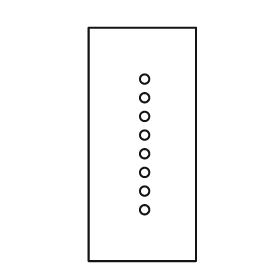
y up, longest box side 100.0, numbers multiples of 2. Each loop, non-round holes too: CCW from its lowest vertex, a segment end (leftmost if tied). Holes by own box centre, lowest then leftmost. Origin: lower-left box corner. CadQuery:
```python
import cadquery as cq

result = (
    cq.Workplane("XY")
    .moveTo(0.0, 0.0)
    .lineTo(46.0, 0.0)
    .lineTo(46.0, 100.0)
    .lineTo(0.0, 100.0)
    .close()
    .moveTo(24.0, 22.0)
    .circle(2.0)
    .moveTo(24.0, 30.0)
    .circle(2.0)
    .moveTo(24.0, 38.0)
    .circle(2.0)
    .moveTo(24.0, 46.0)
    .circle(2.0)
    .moveTo(24.0, 54.0)
    .circle(2.0)
    .moveTo(24.0, 62.0)
    .circle(2.0)
    .moveTo(24.0, 70.0)
    .circle(2.0)
    .moveTo(24.0, 78.0)
    .circle(2.0)
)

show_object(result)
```